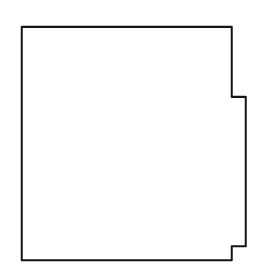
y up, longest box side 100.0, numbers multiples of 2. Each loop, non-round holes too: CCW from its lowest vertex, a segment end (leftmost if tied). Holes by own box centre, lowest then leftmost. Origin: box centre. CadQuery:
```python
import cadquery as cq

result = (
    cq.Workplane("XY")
    .moveTo(-48.0, -50.0)
    .lineTo(42.0, -50.0)
    .lineTo(42.0, -44.0)
    .lineTo(48.0, -44.0)
    .lineTo(48.0, 20.0)
    .lineTo(42.0, 20.0)
    .lineTo(42.0, 50.0)
    .lineTo(-48.0, 50.0)
    .close()
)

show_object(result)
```